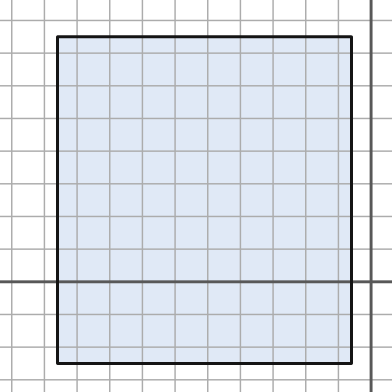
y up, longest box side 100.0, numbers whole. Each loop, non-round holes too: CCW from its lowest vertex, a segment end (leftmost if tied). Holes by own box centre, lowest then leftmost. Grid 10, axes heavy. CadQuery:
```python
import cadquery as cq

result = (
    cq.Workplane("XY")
    .moveTo(-96.0, -25.0)
    .lineTo(-6.0, -25.0)
    .lineTo(-6.0, 75.0)
    .lineTo(-96.0, 75.0)
    .close()
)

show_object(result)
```